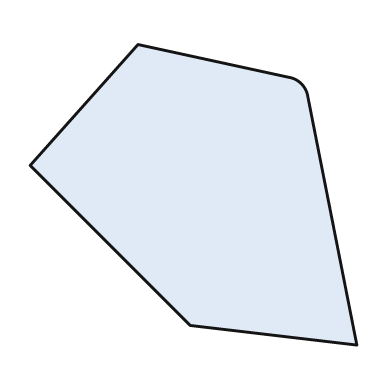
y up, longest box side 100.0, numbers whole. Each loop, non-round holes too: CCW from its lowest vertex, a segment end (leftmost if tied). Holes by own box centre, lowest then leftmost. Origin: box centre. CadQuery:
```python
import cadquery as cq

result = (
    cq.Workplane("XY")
    .moveTo(50.0, -46.0)
    .lineTo(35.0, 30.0)
    .threePointArc((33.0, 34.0), (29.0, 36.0))
    .lineTo(-17.0, 46.0)
    .lineTo(-50.0, 9.0)
    .lineTo(-1.0, -40.0)
    .close()
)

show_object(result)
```